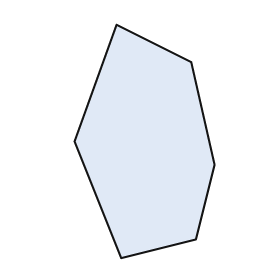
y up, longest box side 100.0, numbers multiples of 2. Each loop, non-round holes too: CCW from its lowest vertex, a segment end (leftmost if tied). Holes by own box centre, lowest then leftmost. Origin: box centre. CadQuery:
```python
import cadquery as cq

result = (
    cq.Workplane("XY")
    .moveTo(-10.0, -50.0)
    .lineTo(22.0, -42.0)
    .lineTo(30.0, -10.0)
    .lineTo(20.0, 34.0)
    .lineTo(-12.0, 50.0)
    .lineTo(-30.0, 0.0)
    .close()
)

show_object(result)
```